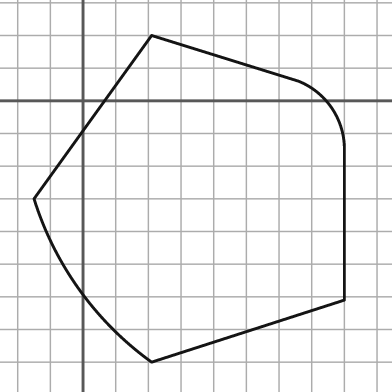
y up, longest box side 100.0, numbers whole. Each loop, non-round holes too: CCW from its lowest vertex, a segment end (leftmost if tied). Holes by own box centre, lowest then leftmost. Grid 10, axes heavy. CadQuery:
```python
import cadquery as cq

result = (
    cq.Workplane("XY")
    .moveTo(21.0, -80.0)
    .lineTo(80.0, -61.0)
    .lineTo(80.0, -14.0)
    .threePointArc((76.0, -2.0), (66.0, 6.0))
    .lineTo(21.0, 20.0)
    .lineTo(-15.0, -30.0)
    .threePointArc((-1.0, -58.0), (21.0, -80.0))
    .close()
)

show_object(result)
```